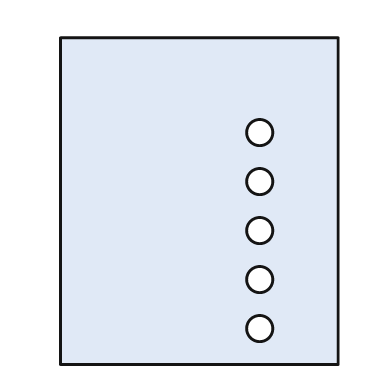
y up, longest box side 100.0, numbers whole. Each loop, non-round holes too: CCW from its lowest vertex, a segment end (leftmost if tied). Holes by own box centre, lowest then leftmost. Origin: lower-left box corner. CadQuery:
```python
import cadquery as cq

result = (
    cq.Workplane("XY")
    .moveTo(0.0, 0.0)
    .lineTo(85.0, 0.0)
    .lineTo(85.0, 100.0)
    .lineTo(0.0, 100.0)
    .close()
    .moveTo(61.0, 11.0)
    .circle(4.0)
    .moveTo(61.0, 26.0)
    .circle(4.0)
    .moveTo(61.0, 41.0)
    .circle(4.0)
    .moveTo(61.0, 56.0)
    .circle(4.0)
    .moveTo(61.0, 71.0)
    .circle(4.0)
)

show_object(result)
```